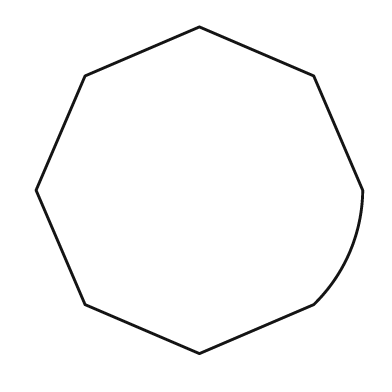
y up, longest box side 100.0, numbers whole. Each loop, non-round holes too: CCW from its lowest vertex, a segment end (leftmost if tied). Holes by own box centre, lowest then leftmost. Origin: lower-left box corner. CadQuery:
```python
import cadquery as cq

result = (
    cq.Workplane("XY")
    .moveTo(50.0, 0.0)
    .lineTo(85.0, 15.0)
    .threePointArc((96.0, 31.0), (100.0, 50.0))
    .lineTo(85.0, 85.0)
    .lineTo(50.0, 100.0)
    .lineTo(15.0, 85.0)
    .lineTo(0.0, 50.0)
    .lineTo(15.0, 15.0)
    .close()
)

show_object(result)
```